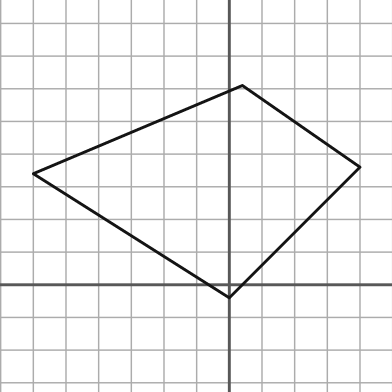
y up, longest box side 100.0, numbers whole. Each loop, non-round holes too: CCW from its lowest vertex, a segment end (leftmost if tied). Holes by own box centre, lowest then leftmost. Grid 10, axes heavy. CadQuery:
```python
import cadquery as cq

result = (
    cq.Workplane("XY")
    .moveTo(0.0, -4.0)
    .lineTo(40.0, 36.0)
    .lineTo(4.0, 61.0)
    .lineTo(-60.0, 34.0)
    .close()
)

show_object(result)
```